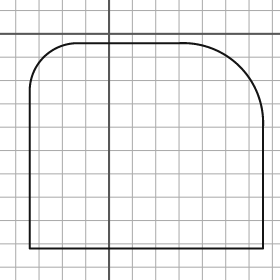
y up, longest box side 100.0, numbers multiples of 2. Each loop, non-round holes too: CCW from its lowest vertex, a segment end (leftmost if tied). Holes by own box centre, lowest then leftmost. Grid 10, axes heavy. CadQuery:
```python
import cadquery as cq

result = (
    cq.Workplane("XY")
    .moveTo(-34.0, -92.0)
    .lineTo(66.0, -92.0)
    .lineTo(66.0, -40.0)
    .threePointArc((56.0, -14.0), (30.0, -4.0))
    .lineTo(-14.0, -4.0)
    .threePointArc((-28.0, -10.0), (-34.0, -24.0))
    .close()
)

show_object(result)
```